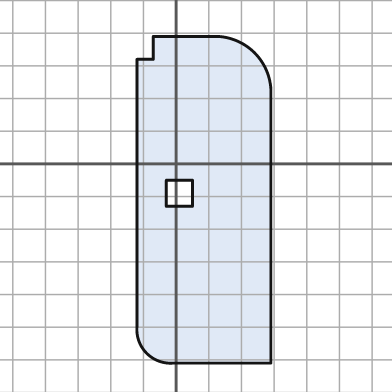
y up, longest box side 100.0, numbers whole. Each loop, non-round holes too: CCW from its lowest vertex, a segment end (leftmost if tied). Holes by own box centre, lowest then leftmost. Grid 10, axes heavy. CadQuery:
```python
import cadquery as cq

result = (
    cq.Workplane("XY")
    .moveTo(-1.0, -61.0)
    .lineTo(29.0, -61.0)
    .lineTo(29.0, 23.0)
    .threePointArc((24.0, 34.0), (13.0, 39.0))
    .lineTo(-7.0, 39.0)
    .lineTo(-7.0, 32.0)
    .lineTo(-12.0, 32.0)
    .lineTo(-12.0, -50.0)
    .threePointArc((-9.0, -58.0), (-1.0, -61.0))
    .close()
    .moveTo(-3.0, -13.0)
    .lineTo(5.0, -13.0)
    .lineTo(5.0, -5.0)
    .lineTo(-3.0, -5.0)
    .close()
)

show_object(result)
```